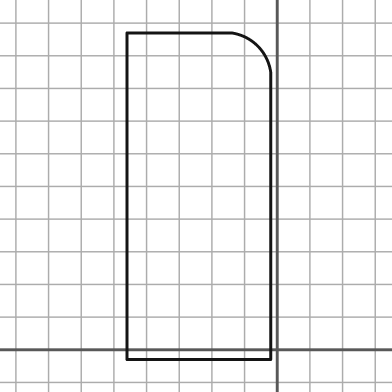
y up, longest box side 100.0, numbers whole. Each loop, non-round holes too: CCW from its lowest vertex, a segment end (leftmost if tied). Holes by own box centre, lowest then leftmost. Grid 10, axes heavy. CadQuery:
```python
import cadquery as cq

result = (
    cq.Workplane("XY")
    .moveTo(-46.0, -3.0)
    .lineTo(-2.0, -3.0)
    .lineTo(-2.0, 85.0)
    .threePointArc((-6.0, 93.0), (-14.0, 97.0))
    .lineTo(-46.0, 97.0)
    .close()
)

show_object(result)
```